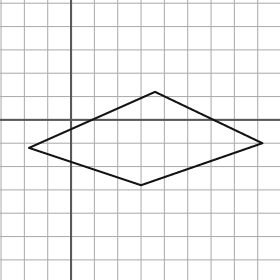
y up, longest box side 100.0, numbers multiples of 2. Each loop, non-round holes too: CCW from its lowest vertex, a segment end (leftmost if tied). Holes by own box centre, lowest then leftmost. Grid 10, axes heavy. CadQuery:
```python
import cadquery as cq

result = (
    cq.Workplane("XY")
    .moveTo(30.0, -28.0)
    .lineTo(82.0, -10.0)
    .lineTo(36.0, 12.0)
    .lineTo(-18.0, -12.0)
    .close()
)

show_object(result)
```